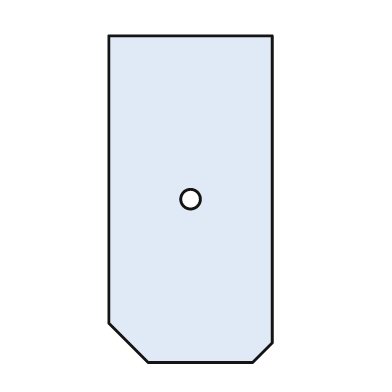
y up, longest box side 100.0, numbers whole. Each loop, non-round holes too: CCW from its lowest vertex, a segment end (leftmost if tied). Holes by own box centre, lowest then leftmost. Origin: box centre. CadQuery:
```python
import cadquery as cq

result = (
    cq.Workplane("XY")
    .moveTo(-13.0, -50.0)
    .lineTo(19.0, -50.0)
    .lineTo(25.0, -44.0)
    .lineTo(25.0, 50.0)
    .lineTo(-25.0, 50.0)
    .lineTo(-25.0, -38.0)
    .close()
    .moveTo(0.0, 0.0)
    .circle(3.0)
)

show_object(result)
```